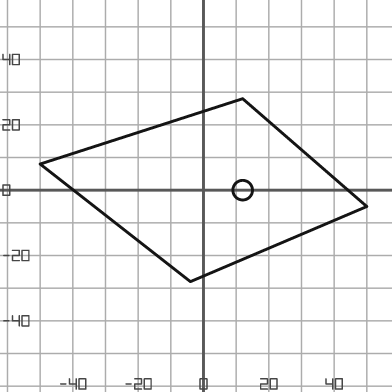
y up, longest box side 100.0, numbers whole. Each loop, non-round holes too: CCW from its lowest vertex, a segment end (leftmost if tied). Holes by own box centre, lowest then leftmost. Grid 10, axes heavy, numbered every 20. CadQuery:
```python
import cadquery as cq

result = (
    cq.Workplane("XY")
    .moveTo(-4.0, -28.0)
    .lineTo(50.0, -5.0)
    .lineTo(12.0, 28.0)
    .lineTo(-50.0, 8.0)
    .close()
    .moveTo(12.0, 0.0)
    .circle(3.0)
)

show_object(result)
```